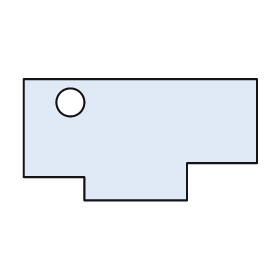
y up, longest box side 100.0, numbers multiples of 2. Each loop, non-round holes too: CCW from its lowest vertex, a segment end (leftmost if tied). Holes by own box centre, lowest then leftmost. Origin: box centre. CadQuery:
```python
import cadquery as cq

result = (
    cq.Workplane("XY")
    .moveTo(-24.0, -26.0)
    .lineTo(20.0, -26.0)
    .lineTo(20.0, -10.0)
    .lineTo(50.0, -10.0)
    .lineTo(50.0, 26.0)
    .lineTo(-50.0, 26.0)
    .lineTo(-50.0, -16.0)
    .lineTo(-24.0, -16.0)
    .close()
    .moveTo(-30.0, 16.0)
    .circle(6.0)
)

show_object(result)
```